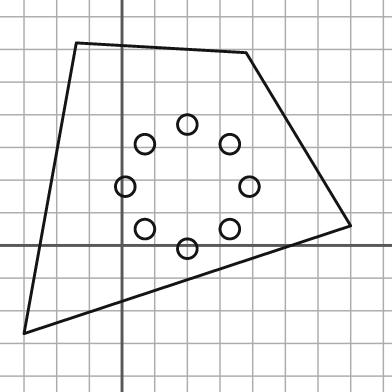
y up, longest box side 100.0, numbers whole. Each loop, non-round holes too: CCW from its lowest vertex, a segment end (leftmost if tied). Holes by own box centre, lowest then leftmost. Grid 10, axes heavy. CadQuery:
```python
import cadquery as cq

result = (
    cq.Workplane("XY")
    .moveTo(-30.0, -27.0)
    .lineTo(70.0, 6.0)
    .lineTo(38.0, 59.0)
    .lineTo(-14.0, 62.0)
    .close()
    .moveTo(20.0, -1.0)
    .circle(3.0)
    .moveTo(7.0, 5.0)
    .circle(3.0)
    .moveTo(33.0, 5.0)
    .circle(3.0)
    .moveTo(1.0, 18.0)
    .circle(3.0)
    .moveTo(39.0, 18.0)
    .circle(3.0)
    .moveTo(7.0, 31.0)
    .circle(3.0)
    .moveTo(33.0, 31.0)
    .circle(3.0)
    .moveTo(20.0, 37.0)
    .circle(3.0)
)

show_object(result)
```